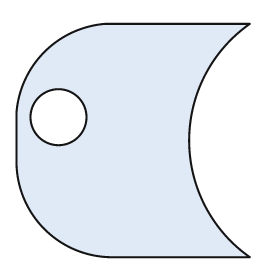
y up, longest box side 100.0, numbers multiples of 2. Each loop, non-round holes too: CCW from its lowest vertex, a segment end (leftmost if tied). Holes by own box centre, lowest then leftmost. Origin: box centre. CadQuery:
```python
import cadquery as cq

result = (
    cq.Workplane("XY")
    .moveTo(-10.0, -50.0)
    .lineTo(50.0, -50.0)
    .threePointArc((24.0, 0.0), (50.0, 50.0))
    .lineTo(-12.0, 50.0)
    .threePointArc((-38.0, 38.0), (-50.0, 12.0))
    .lineTo(-50.0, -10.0)
    .threePointArc((-38.0, -38.0), (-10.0, -50.0))
    .close()
    .moveTo(-32.0, 10.0)
    .circle(12.0)
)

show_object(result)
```